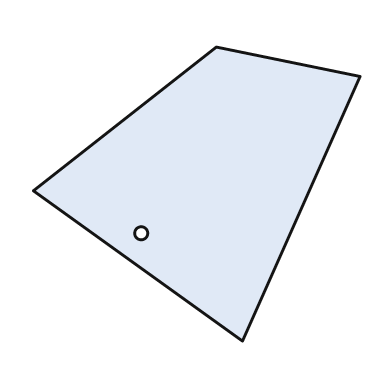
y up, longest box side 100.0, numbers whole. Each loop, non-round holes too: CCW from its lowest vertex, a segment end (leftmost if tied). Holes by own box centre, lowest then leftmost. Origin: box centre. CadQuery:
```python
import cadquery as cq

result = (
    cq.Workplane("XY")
    .moveTo(14.0, -45.0)
    .lineTo(50.0, 36.0)
    .lineTo(6.0, 45.0)
    .lineTo(-50.0, 1.0)
    .close()
    .moveTo(-17.0, -12.0)
    .circle(2.0)
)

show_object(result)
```